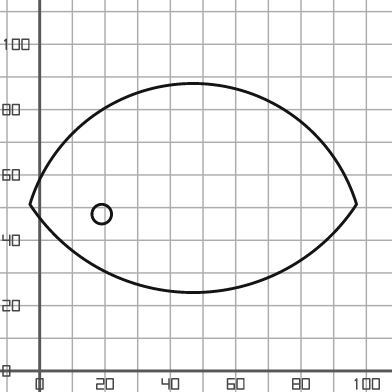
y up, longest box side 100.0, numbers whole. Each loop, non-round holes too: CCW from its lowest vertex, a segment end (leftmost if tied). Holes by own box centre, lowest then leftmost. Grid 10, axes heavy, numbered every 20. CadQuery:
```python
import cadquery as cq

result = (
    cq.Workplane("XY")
    .moveTo(-3.0, 51.0)
    .threePointArc((47.0, 24.0), (97.0, 51.0))
    .threePointArc((47.0, 88.0), (-3.0, 51.0))
    .close()
    .moveTo(19.0, 48.0)
    .circle(3.0)
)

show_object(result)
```